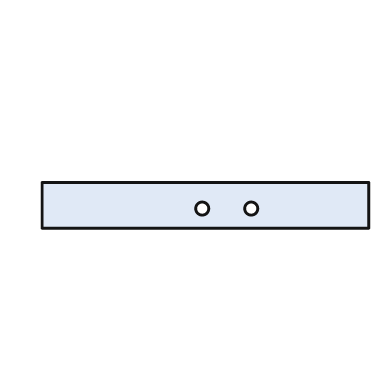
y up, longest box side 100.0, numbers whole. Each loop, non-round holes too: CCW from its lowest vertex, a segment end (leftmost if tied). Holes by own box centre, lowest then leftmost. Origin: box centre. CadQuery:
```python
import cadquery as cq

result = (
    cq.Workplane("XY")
    .moveTo(-50.0, -7.0)
    .lineTo(50.0, -7.0)
    .lineTo(50.0, 7.0)
    .lineTo(-50.0, 7.0)
    .close()
    .moveTo(-1.0, -1.0)
    .circle(2.0)
    .moveTo(14.0, -1.0)
    .circle(2.0)
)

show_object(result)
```